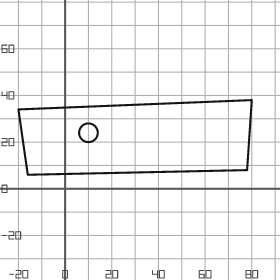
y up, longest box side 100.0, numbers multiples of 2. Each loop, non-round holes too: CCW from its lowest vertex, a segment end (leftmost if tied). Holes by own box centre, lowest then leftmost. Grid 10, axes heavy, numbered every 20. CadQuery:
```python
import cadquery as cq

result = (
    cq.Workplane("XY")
    .moveTo(-16.0, 6.0)
    .lineTo(78.0, 8.0)
    .lineTo(80.0, 38.0)
    .lineTo(-20.0, 34.0)
    .close()
    .moveTo(10.0, 24.0)
    .circle(4.0)
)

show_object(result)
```